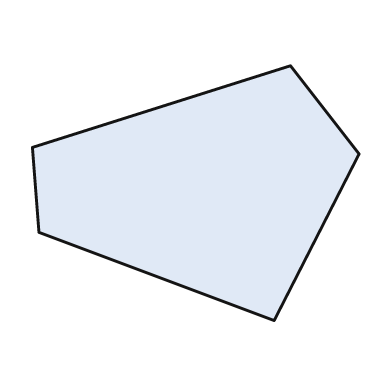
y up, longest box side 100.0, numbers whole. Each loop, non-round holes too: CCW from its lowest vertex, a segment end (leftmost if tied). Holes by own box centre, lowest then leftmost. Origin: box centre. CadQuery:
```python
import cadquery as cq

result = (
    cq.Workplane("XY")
    .moveTo(24.0, -39.0)
    .lineTo(50.0, 12.0)
    .lineTo(29.0, 39.0)
    .lineTo(-50.0, 14.0)
    .lineTo(-48.0, -12.0)
    .close()
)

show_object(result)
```